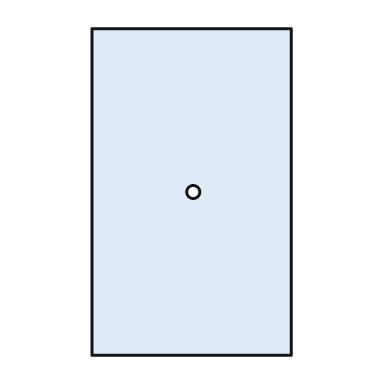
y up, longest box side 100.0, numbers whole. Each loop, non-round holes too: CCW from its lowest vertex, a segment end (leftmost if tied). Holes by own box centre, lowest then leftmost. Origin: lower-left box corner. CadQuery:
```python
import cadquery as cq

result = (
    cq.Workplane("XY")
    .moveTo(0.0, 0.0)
    .lineTo(61.0, 0.0)
    .lineTo(61.0, 100.0)
    .lineTo(0.0, 100.0)
    .close()
    .moveTo(31.0, 50.0)
    .circle(2.0)
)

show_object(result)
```